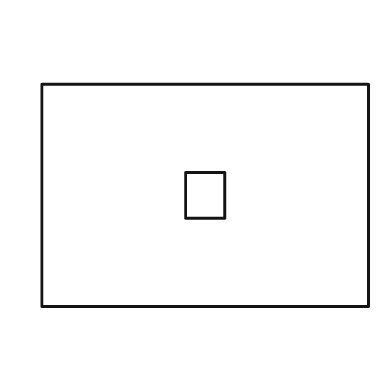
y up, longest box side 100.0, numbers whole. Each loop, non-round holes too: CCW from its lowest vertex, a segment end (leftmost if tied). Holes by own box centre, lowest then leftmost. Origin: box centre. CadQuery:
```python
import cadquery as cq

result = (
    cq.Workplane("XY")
    .moveTo(-50.0, -34.0)
    .lineTo(50.0, -34.0)
    .lineTo(50.0, 34.0)
    .lineTo(-50.0, 34.0)
    .close()
    .moveTo(-6.0, -7.0)
    .lineTo(6.0, -7.0)
    .lineTo(6.0, 7.0)
    .lineTo(-6.0, 7.0)
    .close()
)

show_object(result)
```